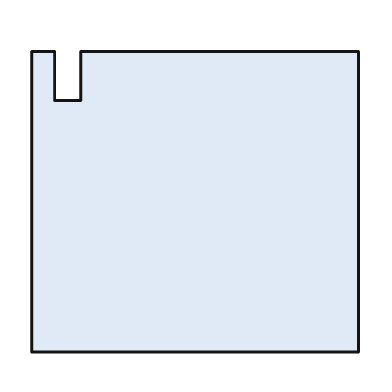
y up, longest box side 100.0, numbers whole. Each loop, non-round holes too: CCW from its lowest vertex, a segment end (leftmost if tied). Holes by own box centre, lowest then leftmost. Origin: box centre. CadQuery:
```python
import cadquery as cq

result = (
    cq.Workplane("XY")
    .moveTo(-50.0, -46.0)
    .lineTo(50.0, -46.0)
    .lineTo(50.0, 46.0)
    .lineTo(-35.0, 46.0)
    .lineTo(-35.0, 31.0)
    .lineTo(-43.0, 31.0)
    .lineTo(-43.0, 46.0)
    .lineTo(-50.0, 46.0)
    .close()
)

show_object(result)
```